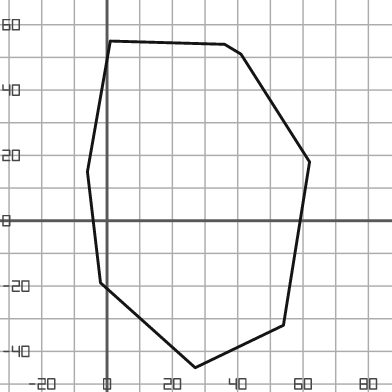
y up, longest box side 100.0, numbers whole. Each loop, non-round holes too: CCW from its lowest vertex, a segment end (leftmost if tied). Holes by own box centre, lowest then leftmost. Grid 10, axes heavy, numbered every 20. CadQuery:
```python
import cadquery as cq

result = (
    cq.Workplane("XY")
    .moveTo(27.0, -45.0)
    .lineTo(54.0, -32.0)
    .lineTo(62.0, 18.0)
    .lineTo(41.0, 51.0)
    .lineTo(36.0, 54.0)
    .lineTo(1.0, 55.0)
    .lineTo(-6.0, 15.0)
    .lineTo(-2.0, -19.0)
    .close()
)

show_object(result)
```